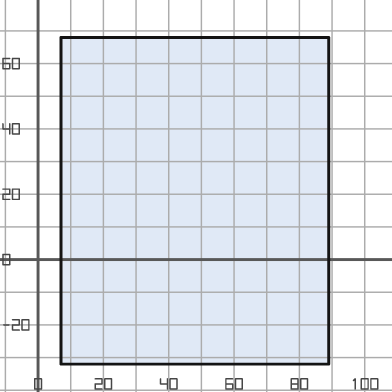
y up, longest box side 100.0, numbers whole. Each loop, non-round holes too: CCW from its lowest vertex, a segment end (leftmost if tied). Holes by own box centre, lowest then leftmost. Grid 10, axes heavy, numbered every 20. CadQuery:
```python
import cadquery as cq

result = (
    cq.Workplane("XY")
    .moveTo(7.0, -32.0)
    .lineTo(89.0, -32.0)
    .lineTo(89.0, 68.0)
    .lineTo(7.0, 68.0)
    .close()
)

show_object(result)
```